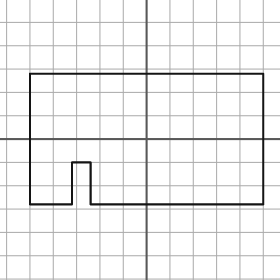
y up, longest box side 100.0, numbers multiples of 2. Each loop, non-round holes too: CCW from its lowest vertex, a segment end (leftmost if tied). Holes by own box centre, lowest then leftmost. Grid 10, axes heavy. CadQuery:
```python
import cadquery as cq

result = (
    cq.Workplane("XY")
    .moveTo(-50.0, -28.0)
    .lineTo(-32.0, -28.0)
    .lineTo(-32.0, -10.0)
    .lineTo(-24.0, -10.0)
    .lineTo(-24.0, -28.0)
    .lineTo(50.0, -28.0)
    .lineTo(50.0, 28.0)
    .lineTo(-50.0, 28.0)
    .close()
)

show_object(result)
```